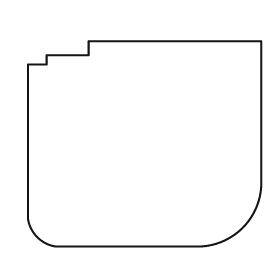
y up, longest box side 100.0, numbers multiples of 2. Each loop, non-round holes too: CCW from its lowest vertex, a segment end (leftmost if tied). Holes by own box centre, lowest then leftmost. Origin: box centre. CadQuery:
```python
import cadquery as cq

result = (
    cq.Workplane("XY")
    .moveTo(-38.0, -44.0)
    .lineTo(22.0, -44.0)
    .threePointArc((42.0, -36.0), (50.0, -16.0))
    .lineTo(50.0, 44.0)
    .lineTo(-24.0, 44.0)
    .lineTo(-24.0, 38.0)
    .lineTo(-42.0, 38.0)
    .lineTo(-42.0, 34.0)
    .lineTo(-50.0, 34.0)
    .lineTo(-50.0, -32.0)
    .threePointArc((-46.0, -40.0), (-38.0, -44.0))
    .close()
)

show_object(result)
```